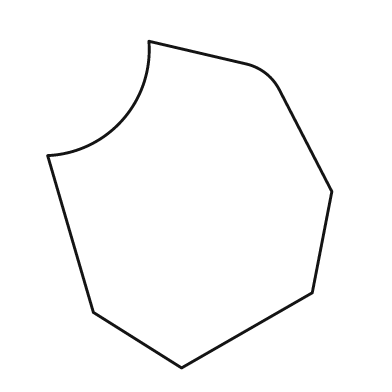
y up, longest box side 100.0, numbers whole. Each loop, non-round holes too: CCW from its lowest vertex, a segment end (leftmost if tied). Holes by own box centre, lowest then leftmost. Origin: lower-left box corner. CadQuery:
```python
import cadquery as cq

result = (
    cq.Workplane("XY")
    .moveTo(41.0, 0.0)
    .lineTo(81.0, 23.0)
    .lineTo(87.0, 54.0)
    .lineTo(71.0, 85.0)
    .threePointArc((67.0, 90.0), (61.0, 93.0))
    .lineTo(31.0, 100.0)
    .threePointArc((23.0, 76.0), (0.0, 65.0))
    .lineTo(14.0, 17.0)
    .close()
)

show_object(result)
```